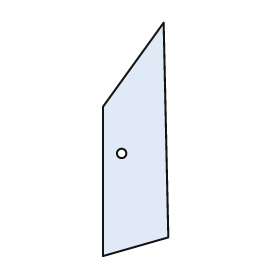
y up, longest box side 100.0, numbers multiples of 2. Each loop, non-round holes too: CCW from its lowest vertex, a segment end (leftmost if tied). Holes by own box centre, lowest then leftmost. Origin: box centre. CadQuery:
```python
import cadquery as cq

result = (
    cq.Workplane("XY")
    .moveTo(-14.0, -50.0)
    .lineTo(14.0, -42.0)
    .lineTo(12.0, 50.0)
    .lineTo(-14.0, 14.0)
    .close()
    .moveTo(-6.0, -6.0)
    .circle(2.0)
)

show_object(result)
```